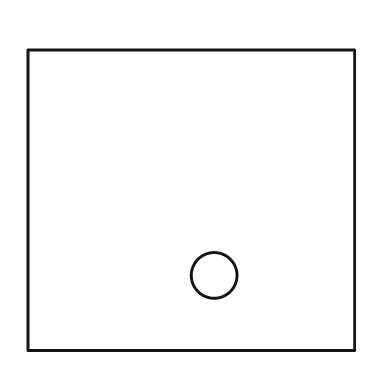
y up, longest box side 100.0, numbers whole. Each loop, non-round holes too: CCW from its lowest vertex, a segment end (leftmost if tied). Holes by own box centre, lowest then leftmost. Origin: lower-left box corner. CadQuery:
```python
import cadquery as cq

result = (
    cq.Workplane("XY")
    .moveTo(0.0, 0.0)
    .lineTo(100.0, 0.0)
    .lineTo(100.0, 92.0)
    .lineTo(0.0, 92.0)
    .close()
    .moveTo(57.0, 23.0)
    .circle(7.0)
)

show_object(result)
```